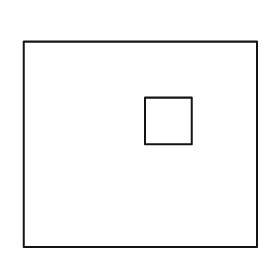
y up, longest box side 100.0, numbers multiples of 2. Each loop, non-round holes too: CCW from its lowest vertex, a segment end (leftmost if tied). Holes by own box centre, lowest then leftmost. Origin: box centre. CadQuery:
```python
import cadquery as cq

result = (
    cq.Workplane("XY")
    .moveTo(-50.0, -44.0)
    .lineTo(50.0, -44.0)
    .lineTo(50.0, 44.0)
    .lineTo(-50.0, 44.0)
    .close()
    .moveTo(2.0, 0.0)
    .lineTo(22.0, 0.0)
    .lineTo(22.0, 20.0)
    .lineTo(2.0, 20.0)
    .close()
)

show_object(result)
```